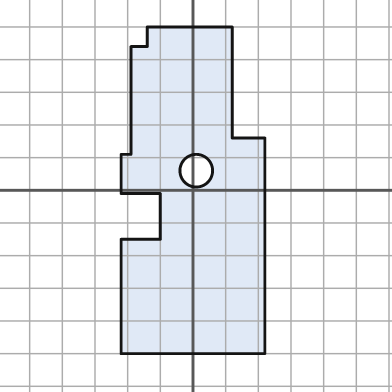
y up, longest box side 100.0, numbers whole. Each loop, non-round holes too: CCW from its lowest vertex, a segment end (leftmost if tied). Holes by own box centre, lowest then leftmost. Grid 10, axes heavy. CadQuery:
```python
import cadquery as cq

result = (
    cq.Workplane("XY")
    .moveTo(-22.0, -50.0)
    .lineTo(22.0, -50.0)
    .lineTo(22.0, 16.0)
    .lineTo(12.0, 16.0)
    .lineTo(12.0, 50.0)
    .lineTo(-14.0, 50.0)
    .lineTo(-14.0, 44.0)
    .lineTo(-19.0, 44.0)
    .lineTo(-19.0, 11.0)
    .lineTo(-22.0, 11.0)
    .lineTo(-22.0, -1.0)
    .lineTo(-10.0, -1.0)
    .lineTo(-10.0, -15.0)
    .lineTo(-22.0, -15.0)
    .close()
    .moveTo(1.0, 6.0)
    .circle(5.0)
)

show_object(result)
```